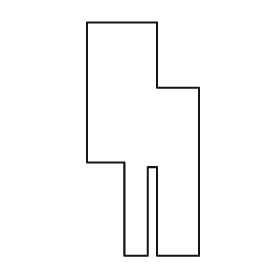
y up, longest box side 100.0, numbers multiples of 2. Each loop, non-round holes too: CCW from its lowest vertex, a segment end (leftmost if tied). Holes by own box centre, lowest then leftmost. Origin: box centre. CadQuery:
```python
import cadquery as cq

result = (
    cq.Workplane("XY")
    .moveTo(-8.0, -50.0)
    .lineTo(2.0, -50.0)
    .lineTo(2.0, -12.0)
    .lineTo(6.0, -12.0)
    .lineTo(6.0, -50.0)
    .lineTo(24.0, -50.0)
    .lineTo(24.0, 22.0)
    .lineTo(6.0, 22.0)
    .lineTo(6.0, 50.0)
    .lineTo(-24.0, 50.0)
    .lineTo(-24.0, -10.0)
    .lineTo(-8.0, -10.0)
    .close()
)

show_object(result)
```